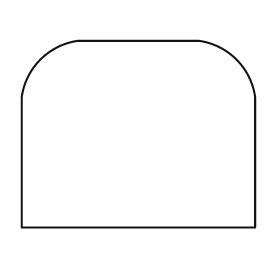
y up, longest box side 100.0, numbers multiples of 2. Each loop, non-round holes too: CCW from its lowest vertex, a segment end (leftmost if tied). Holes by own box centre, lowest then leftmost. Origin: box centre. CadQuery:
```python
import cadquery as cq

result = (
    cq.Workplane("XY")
    .moveTo(-50.0, -40.0)
    .lineTo(50.0, -40.0)
    .lineTo(50.0, 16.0)
    .threePointArc((42.0, 32.0), (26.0, 40.0))
    .lineTo(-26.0, 40.0)
    .threePointArc((-42.0, 32.0), (-50.0, 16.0))
    .close()
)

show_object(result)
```